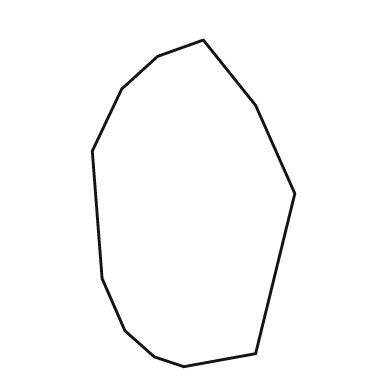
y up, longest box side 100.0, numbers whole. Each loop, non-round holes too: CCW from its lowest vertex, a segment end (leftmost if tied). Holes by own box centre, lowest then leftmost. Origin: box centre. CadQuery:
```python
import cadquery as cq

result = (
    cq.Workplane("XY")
    .moveTo(-3.0, -50.0)
    .lineTo(19.0, -46.0)
    .lineTo(31.0, 3.0)
    .lineTo(19.0, 30.0)
    .lineTo(3.0, 50.0)
    .lineTo(-11.0, 45.0)
    .lineTo(-22.0, 35.0)
    .lineTo(-31.0, 16.0)
    .lineTo(-28.0, -23.0)
    .lineTo(-21.0, -39.0)
    .lineTo(-12.0, -47.0)
    .close()
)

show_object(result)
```